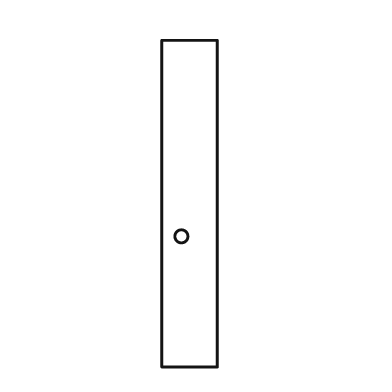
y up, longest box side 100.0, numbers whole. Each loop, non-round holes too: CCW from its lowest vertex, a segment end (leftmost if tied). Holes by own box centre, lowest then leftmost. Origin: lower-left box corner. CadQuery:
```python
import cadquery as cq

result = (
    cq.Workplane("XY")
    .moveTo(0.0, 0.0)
    .lineTo(17.0, 0.0)
    .lineTo(17.0, 100.0)
    .lineTo(0.0, 100.0)
    .close()
    .moveTo(6.0, 40.0)
    .circle(2.0)
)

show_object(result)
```